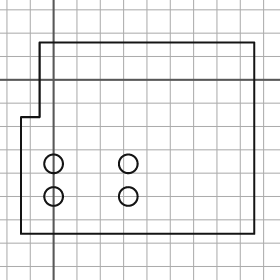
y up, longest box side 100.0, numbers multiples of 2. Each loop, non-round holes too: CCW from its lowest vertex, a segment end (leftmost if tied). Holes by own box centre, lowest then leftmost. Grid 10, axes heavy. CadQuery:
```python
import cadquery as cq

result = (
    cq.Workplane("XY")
    .moveTo(-14.0, -66.0)
    .lineTo(86.0, -66.0)
    .lineTo(86.0, 16.0)
    .lineTo(-6.0, 16.0)
    .lineTo(-6.0, -16.0)
    .lineTo(-14.0, -16.0)
    .close()
    .moveTo(0.0, -50.0)
    .circle(4.0)
    .moveTo(32.0, -50.0)
    .circle(4.0)
    .moveTo(0.0, -36.0)
    .circle(4.0)
    .moveTo(32.0, -36.0)
    .circle(4.0)
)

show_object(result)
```